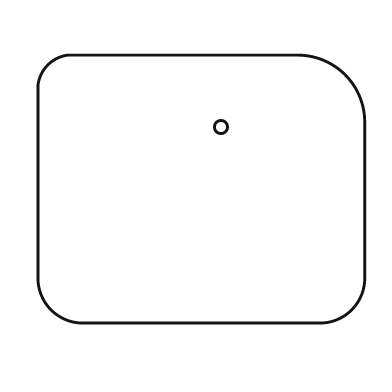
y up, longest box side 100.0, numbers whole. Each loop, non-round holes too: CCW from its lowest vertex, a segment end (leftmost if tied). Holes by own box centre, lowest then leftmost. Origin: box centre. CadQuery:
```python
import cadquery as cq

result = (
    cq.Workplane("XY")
    .moveTo(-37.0, -41.0)
    .lineTo(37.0, -41.0)
    .threePointArc((46.0, -37.0), (50.0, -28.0))
    .lineTo(50.0, 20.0)
    .threePointArc((44.0, 35.0), (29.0, 41.0))
    .lineTo(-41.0, 41.0)
    .threePointArc((-47.0, 38.0), (-50.0, 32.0))
    .lineTo(-50.0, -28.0)
    .threePointArc((-46.0, -37.0), (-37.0, -41.0))
    .close()
    .moveTo(6.0, 19.0)
    .circle(2.0)
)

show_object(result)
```